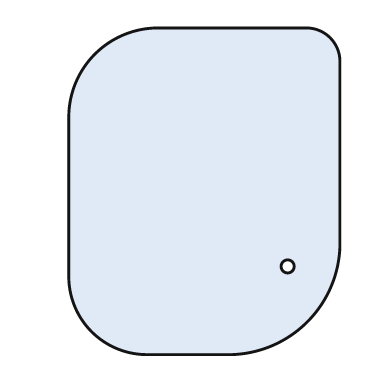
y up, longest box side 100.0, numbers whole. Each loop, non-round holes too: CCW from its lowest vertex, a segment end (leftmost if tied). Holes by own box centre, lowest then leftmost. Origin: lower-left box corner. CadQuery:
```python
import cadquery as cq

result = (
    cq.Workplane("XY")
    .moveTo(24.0, 0.0)
    .lineTo(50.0, 0.0)
    .threePointArc((73.0, 10.0), (83.0, 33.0))
    .lineTo(83.0, 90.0)
    .threePointArc((80.0, 97.0), (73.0, 100.0))
    .lineTo(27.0, 100.0)
    .threePointArc((8.0, 92.0), (0.0, 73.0))
    .lineTo(0.0, 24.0)
    .threePointArc((7.0, 7.0), (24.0, 0.0))
    .close()
    .moveTo(67.0, 27.0)
    .circle(2.0)
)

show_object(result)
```